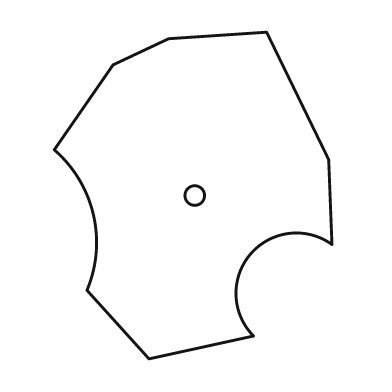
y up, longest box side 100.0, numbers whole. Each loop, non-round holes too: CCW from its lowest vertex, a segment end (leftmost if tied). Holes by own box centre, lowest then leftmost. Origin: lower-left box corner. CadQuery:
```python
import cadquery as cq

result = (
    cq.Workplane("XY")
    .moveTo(29.0, 0.0)
    .lineTo(61.0, 7.0)
    .threePointArc((60.0, 32.0), (85.0, 35.0))
    .lineTo(84.0, 61.0)
    .lineTo(65.0, 100.0)
    .lineTo(35.0, 98.0)
    .lineTo(18.0, 90.0)
    .lineTo(0.0, 64.0)
    .threePointArc((12.0, 44.0), (10.0, 21.0))
    .close()
    .moveTo(43.0, 50.0)
    .circle(3.0)
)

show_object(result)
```